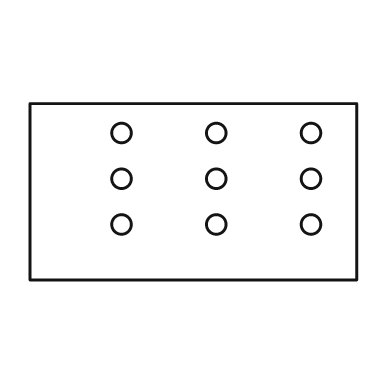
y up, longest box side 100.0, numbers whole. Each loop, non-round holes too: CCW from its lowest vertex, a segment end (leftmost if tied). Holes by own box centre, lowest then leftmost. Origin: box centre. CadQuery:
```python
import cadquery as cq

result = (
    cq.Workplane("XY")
    .moveTo(-50.0, -27.0)
    .lineTo(50.0, -27.0)
    .lineTo(50.0, 27.0)
    .lineTo(-50.0, 27.0)
    .close()
    .moveTo(-22.0, -10.0)
    .circle(3.0)
    .moveTo(7.0, -10.0)
    .circle(3.0)
    .moveTo(36.0, -10.0)
    .circle(3.0)
    .moveTo(-22.0, 4.0)
    .circle(3.0)
    .moveTo(7.0, 4.0)
    .circle(3.0)
    .moveTo(36.0, 4.0)
    .circle(3.0)
    .moveTo(-22.0, 18.0)
    .circle(3.0)
    .moveTo(7.0, 18.0)
    .circle(3.0)
    .moveTo(36.0, 18.0)
    .circle(3.0)
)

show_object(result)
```